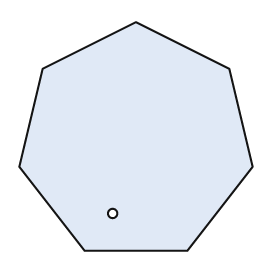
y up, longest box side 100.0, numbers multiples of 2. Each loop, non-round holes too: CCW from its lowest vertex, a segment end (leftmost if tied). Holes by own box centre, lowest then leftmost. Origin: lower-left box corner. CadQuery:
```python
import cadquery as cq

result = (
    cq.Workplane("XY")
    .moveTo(28.0, 0.0)
    .lineTo(72.0, 0.0)
    .lineTo(100.0, 36.0)
    .lineTo(90.0, 78.0)
    .lineTo(50.0, 98.0)
    .lineTo(10.0, 78.0)
    .lineTo(0.0, 36.0)
    .close()
    .moveTo(40.0, 16.0)
    .circle(2.0)
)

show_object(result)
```